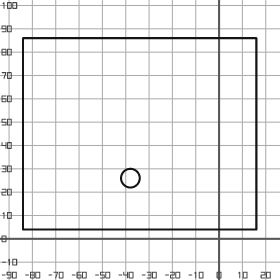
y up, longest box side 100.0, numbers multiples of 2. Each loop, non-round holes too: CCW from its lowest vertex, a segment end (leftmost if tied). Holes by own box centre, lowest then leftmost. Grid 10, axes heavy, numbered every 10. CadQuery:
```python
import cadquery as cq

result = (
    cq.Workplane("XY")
    .moveTo(-84.0, 4.0)
    .lineTo(16.0, 4.0)
    .lineTo(16.0, 86.0)
    .lineTo(-84.0, 86.0)
    .close()
    .moveTo(-38.0, 26.0)
    .circle(4.0)
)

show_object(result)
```